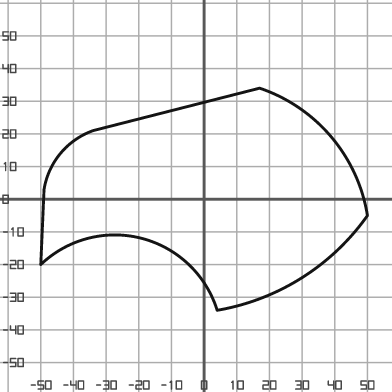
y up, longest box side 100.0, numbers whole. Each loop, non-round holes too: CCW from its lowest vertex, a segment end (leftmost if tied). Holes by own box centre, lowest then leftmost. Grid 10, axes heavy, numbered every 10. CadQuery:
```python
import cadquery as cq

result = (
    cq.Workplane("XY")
    .moveTo(4.0, -34.0)
    .threePointArc((30.0, -24.0), (50.0, -5.0))
    .threePointArc((39.0, 19.0), (17.0, 34.0))
    .lineTo(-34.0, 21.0)
    .threePointArc((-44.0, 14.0), (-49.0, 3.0))
    .lineTo(-50.0, -20.0)
    .threePointArc((-19.0, -12.0), (4.0, -34.0))
    .close()
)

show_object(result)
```